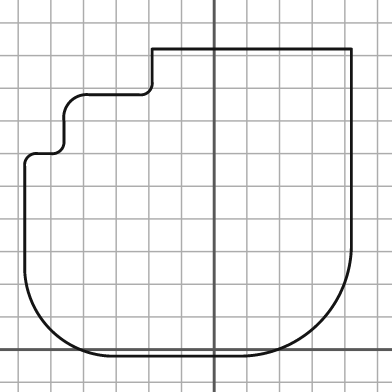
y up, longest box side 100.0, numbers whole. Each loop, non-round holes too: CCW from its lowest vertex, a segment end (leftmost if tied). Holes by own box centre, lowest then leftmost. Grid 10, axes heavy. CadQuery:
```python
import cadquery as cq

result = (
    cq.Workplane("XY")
    .moveTo(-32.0, -2.0)
    .lineTo(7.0, -2.0)
    .threePointArc((32.0, 8.0), (42.0, 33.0))
    .lineTo(42.0, 92.0)
    .lineTo(-19.0, 92.0)
    .lineTo(-19.0, 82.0)
    .threePointArc((-20.0, 79.0), (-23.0, 78.0))
    .lineTo(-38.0, 78.0)
    .threePointArc((-44.0, 76.0), (-46.0, 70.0))
    .lineTo(-46.0, 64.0)
    .threePointArc((-47.0, 61.0), (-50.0, 60.0))
    .lineTo(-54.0, 60.0)
    .threePointArc((-57.0, 59.0), (-58.0, 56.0))
    .lineTo(-58.0, 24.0)
    .threePointArc((-50.0, 6.0), (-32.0, -2.0))
    .close()
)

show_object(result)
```